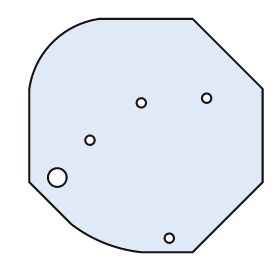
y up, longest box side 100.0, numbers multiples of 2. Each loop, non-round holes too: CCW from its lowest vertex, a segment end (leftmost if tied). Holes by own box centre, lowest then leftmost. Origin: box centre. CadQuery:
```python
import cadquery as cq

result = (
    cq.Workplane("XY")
    .moveTo(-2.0, -50.0)
    .lineTo(20.0, -50.0)
    .lineTo(50.0, -20.0)
    .lineTo(50.0, 20.0)
    .lineTo(20.0, 50.0)
    .lineTo(-20.0, 50.0)
    .threePointArc((-40.0, 40.0), (-50.0, 20.0))
    .lineTo(-50.0, -20.0)
    .lineTo(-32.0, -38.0)
    .threePointArc((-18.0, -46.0), (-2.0, -50.0))
    .close()
    .moveTo(10.0, -44.0)
    .circle(2.0)
    .moveTo(-38.0, -18.0)
    .circle(4.0)
    .moveTo(-24.0, -2.0)
    .circle(2.0)
    .moveTo(-2.0, 14.0)
    .circle(2.0)
    .moveTo(26.0, 16.0)
    .circle(2.0)
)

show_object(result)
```